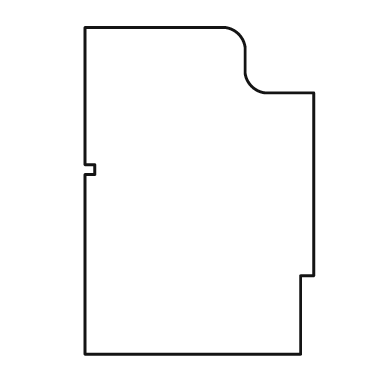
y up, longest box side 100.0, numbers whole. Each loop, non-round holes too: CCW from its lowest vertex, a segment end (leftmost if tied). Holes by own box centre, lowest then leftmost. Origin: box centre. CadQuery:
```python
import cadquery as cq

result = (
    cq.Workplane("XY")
    .moveTo(-35.0, -50.0)
    .lineTo(31.0, -50.0)
    .lineTo(31.0, -26.0)
    .lineTo(35.0, -26.0)
    .lineTo(35.0, 30.0)
    .lineTo(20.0, 30.0)
    .threePointArc((16.0, 32.0), (14.0, 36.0))
    .lineTo(14.0, 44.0)
    .threePointArc((12.0, 48.0), (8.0, 50.0))
    .lineTo(-35.0, 50.0)
    .lineTo(-35.0, 8.0)
    .lineTo(-32.0, 8.0)
    .lineTo(-32.0, 5.0)
    .lineTo(-35.0, 5.0)
    .close()
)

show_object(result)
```